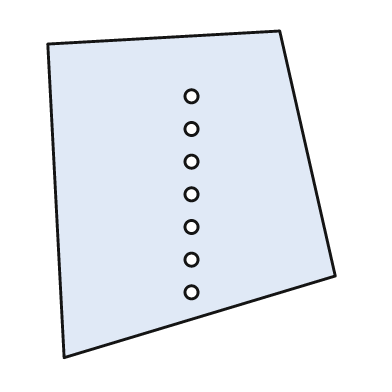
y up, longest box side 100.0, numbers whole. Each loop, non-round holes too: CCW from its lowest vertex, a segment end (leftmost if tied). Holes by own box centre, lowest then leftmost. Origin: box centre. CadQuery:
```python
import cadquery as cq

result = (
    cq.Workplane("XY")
    .moveTo(-39.0, -50.0)
    .lineTo(44.0, -25.0)
    .lineTo(27.0, 50.0)
    .lineTo(-44.0, 46.0)
    .close()
    .moveTo(0.0, -30.0)
    .circle(2.0)
    .moveTo(0.0, -20.0)
    .circle(2.0)
    .moveTo(0.0, -10.0)
    .circle(2.0)
    .moveTo(0.0, 0.0)
    .circle(2.0)
    .moveTo(0.0, 10.0)
    .circle(2.0)
    .moveTo(0.0, 20.0)
    .circle(2.0)
    .moveTo(0.0, 30.0)
    .circle(2.0)
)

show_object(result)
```